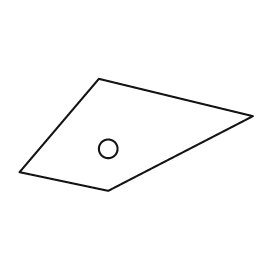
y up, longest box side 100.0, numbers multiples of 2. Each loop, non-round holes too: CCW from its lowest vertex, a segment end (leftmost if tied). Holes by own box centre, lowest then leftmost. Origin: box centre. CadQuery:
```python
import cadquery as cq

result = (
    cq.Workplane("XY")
    .moveTo(-12.0, -24.0)
    .lineTo(50.0, 8.0)
    .lineTo(-16.0, 24.0)
    .lineTo(-50.0, -16.0)
    .close()
    .moveTo(-12.0, -6.0)
    .circle(4.0)
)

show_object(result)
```